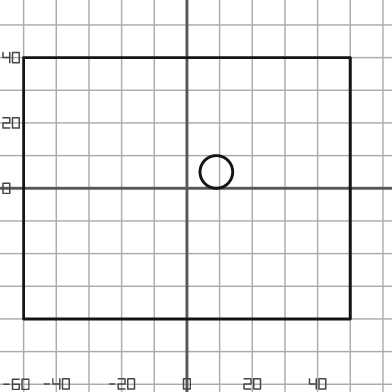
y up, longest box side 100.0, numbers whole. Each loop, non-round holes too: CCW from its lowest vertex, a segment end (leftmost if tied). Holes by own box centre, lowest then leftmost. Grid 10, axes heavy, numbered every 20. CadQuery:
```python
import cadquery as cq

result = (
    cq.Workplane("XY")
    .moveTo(-50.0, -40.0)
    .lineTo(50.0, -40.0)
    .lineTo(50.0, 40.0)
    .lineTo(-50.0, 40.0)
    .close()
    .moveTo(9.0, 5.0)
    .circle(5.0)
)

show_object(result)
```